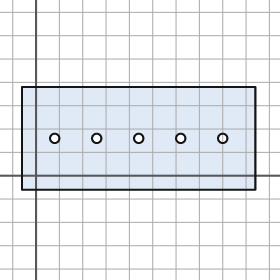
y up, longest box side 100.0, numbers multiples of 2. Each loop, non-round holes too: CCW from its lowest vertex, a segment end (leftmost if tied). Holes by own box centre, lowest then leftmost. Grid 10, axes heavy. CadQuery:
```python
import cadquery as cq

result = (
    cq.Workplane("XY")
    .moveTo(-6.0, -6.0)
    .lineTo(94.0, -6.0)
    .lineTo(94.0, 38.0)
    .lineTo(-6.0, 38.0)
    .close()
    .moveTo(8.0, 16.0)
    .circle(2.0)
    .moveTo(26.0, 16.0)
    .circle(2.0)
    .moveTo(44.0, 16.0)
    .circle(2.0)
    .moveTo(62.0, 16.0)
    .circle(2.0)
    .moveTo(80.0, 16.0)
    .circle(2.0)
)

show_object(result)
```